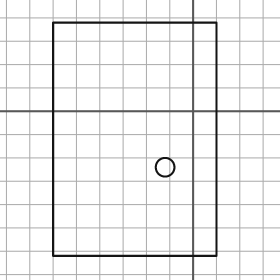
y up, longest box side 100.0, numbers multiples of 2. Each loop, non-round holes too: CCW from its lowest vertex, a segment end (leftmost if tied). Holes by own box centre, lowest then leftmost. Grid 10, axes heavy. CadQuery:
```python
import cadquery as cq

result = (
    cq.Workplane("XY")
    .moveTo(-60.0, -62.0)
    .lineTo(10.0, -62.0)
    .lineTo(10.0, 38.0)
    .lineTo(-60.0, 38.0)
    .close()
    .moveTo(-12.0, -24.0)
    .circle(4.0)
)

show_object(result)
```